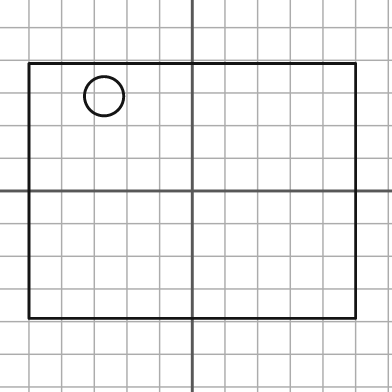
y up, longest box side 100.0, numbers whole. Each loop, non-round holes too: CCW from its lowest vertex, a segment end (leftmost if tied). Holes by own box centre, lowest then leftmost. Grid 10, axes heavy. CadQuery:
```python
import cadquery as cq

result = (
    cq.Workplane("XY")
    .moveTo(-50.0, -39.0)
    .lineTo(50.0, -39.0)
    .lineTo(50.0, 39.0)
    .lineTo(-50.0, 39.0)
    .close()
    .moveTo(-27.0, 29.0)
    .circle(6.0)
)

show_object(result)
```